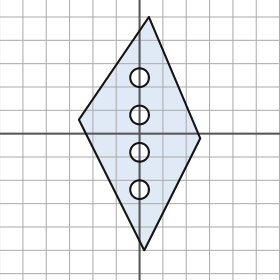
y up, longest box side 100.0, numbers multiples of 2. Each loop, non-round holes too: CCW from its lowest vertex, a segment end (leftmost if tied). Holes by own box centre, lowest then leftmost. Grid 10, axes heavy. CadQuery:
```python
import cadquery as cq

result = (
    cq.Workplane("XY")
    .moveTo(2.0, -50.0)
    .lineTo(26.0, -2.0)
    .lineTo(4.0, 50.0)
    .lineTo(-26.0, 6.0)
    .close()
    .moveTo(0.0, -24.0)
    .circle(4.0)
    .moveTo(0.0, -8.0)
    .circle(4.0)
    .moveTo(0.0, 8.0)
    .circle(4.0)
    .moveTo(0.0, 24.0)
    .circle(4.0)
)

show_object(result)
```